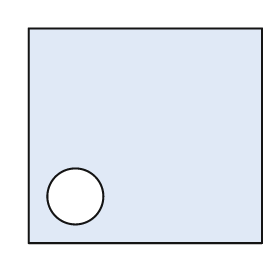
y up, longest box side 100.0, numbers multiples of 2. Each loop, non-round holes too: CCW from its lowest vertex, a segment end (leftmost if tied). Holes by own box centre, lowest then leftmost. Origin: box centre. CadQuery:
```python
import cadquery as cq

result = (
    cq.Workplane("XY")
    .moveTo(-50.0, -46.0)
    .lineTo(50.0, -46.0)
    .lineTo(50.0, 46.0)
    .lineTo(-50.0, 46.0)
    .close()
    .moveTo(-30.0, -26.0)
    .circle(12.0)
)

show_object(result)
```